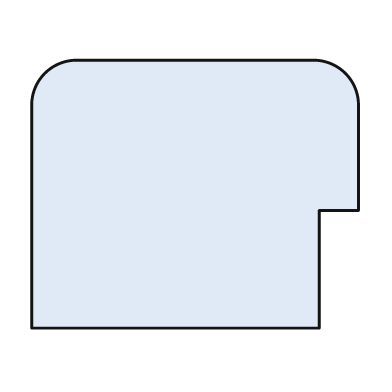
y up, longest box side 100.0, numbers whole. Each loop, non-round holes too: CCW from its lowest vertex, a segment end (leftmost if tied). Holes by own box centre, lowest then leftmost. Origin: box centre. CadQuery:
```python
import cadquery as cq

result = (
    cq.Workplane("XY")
    .moveTo(-50.0, -41.0)
    .lineTo(38.0, -41.0)
    .lineTo(38.0, -5.0)
    .lineTo(50.0, -5.0)
    .lineTo(50.0, 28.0)
    .threePointArc((46.0, 37.0), (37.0, 41.0))
    .lineTo(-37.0, 41.0)
    .threePointArc((-46.0, 37.0), (-50.0, 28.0))
    .close()
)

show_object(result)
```